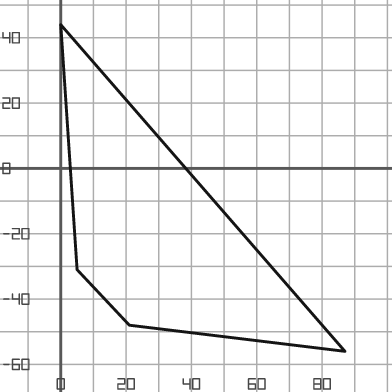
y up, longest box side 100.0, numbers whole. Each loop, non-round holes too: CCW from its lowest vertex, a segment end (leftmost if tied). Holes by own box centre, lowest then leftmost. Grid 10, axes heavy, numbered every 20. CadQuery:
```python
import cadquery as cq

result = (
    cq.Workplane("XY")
    .moveTo(87.0, -56.0)
    .lineTo(0.0, 44.0)
    .lineTo(5.0, -31.0)
    .lineTo(21.0, -48.0)
    .close()
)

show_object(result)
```